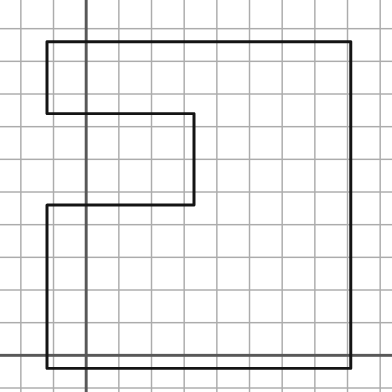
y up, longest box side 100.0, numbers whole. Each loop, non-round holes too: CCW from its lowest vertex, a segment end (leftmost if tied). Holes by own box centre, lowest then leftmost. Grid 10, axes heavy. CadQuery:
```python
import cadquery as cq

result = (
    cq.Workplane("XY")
    .moveTo(-12.0, -4.0)
    .lineTo(81.0, -4.0)
    .lineTo(81.0, 96.0)
    .lineTo(-12.0, 96.0)
    .lineTo(-12.0, 74.0)
    .lineTo(33.0, 74.0)
    .lineTo(33.0, 46.0)
    .lineTo(-12.0, 46.0)
    .close()
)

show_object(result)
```